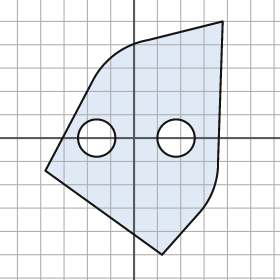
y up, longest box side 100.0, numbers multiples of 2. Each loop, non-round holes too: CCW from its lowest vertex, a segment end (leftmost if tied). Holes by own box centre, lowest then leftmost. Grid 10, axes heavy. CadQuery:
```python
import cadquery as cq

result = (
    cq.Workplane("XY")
    .moveTo(12.0, -50.0)
    .lineTo(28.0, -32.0)
    .threePointArc((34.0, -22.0), (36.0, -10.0))
    .lineTo(38.0, 50.0)
    .lineTo(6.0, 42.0)
    .threePointArc((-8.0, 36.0), (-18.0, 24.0))
    .lineTo(-38.0, -14.0)
    .close()
    .moveTo(-16.0, 0.0)
    .circle(8.0)
    .moveTo(18.0, 0.0)
    .circle(8.0)
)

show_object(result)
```